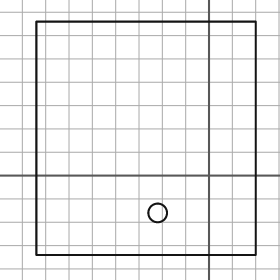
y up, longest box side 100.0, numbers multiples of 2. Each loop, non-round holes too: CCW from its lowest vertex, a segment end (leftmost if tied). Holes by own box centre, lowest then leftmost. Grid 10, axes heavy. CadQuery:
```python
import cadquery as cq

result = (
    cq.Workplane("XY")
    .moveTo(-74.0, -34.0)
    .lineTo(20.0, -34.0)
    .lineTo(20.0, 66.0)
    .lineTo(-74.0, 66.0)
    .close()
    .moveTo(-22.0, -16.0)
    .circle(4.0)
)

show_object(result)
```